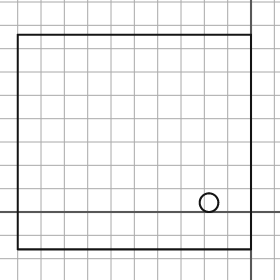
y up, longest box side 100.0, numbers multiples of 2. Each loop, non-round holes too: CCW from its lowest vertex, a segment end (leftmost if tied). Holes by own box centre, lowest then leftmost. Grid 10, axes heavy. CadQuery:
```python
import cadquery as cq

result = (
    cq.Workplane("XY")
    .moveTo(-100.0, -16.0)
    .lineTo(0.0, -16.0)
    .lineTo(0.0, 76.0)
    .lineTo(-100.0, 76.0)
    .close()
    .moveTo(-18.0, 4.0)
    .circle(4.0)
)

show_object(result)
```